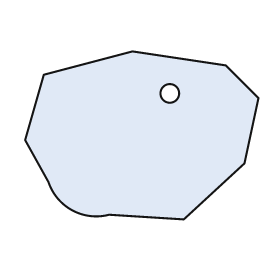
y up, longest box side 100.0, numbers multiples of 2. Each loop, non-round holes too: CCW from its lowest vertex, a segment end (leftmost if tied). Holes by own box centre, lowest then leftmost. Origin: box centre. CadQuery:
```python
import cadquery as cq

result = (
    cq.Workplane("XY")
    .moveTo(18.0, -36.0)
    .lineTo(44.0, -12.0)
    .lineTo(50.0, 16.0)
    .lineTo(36.0, 30.0)
    .lineTo(-4.0, 36.0)
    .lineTo(-42.0, 26.0)
    .lineTo(-50.0, -2.0)
    .lineTo(-40.0, -20.0)
    .threePointArc((-30.0, -32.0), (-14.0, -34.0))
    .close()
    .moveTo(12.0, 18.0)
    .circle(4.0)
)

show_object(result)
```